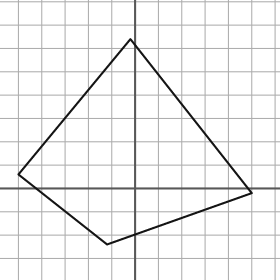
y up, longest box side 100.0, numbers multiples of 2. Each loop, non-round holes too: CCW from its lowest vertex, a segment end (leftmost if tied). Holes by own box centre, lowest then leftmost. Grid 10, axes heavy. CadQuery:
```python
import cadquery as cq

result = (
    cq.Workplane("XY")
    .moveTo(-12.0, -24.0)
    .lineTo(50.0, -2.0)
    .lineTo(-2.0, 64.0)
    .lineTo(-50.0, 6.0)
    .close()
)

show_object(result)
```